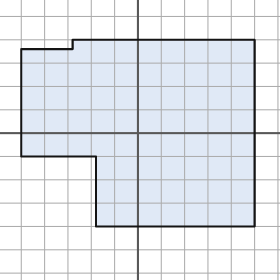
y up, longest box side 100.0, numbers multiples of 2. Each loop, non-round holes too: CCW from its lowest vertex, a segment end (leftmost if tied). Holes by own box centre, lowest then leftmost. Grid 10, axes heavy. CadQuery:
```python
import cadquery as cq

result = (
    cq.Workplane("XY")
    .moveTo(-18.0, -40.0)
    .lineTo(50.0, -40.0)
    .lineTo(50.0, 40.0)
    .lineTo(-28.0, 40.0)
    .lineTo(-28.0, 36.0)
    .lineTo(-50.0, 36.0)
    .lineTo(-50.0, -10.0)
    .lineTo(-18.0, -10.0)
    .close()
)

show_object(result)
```